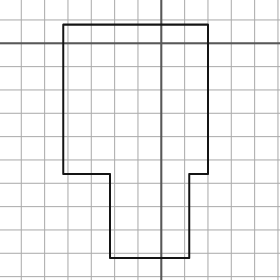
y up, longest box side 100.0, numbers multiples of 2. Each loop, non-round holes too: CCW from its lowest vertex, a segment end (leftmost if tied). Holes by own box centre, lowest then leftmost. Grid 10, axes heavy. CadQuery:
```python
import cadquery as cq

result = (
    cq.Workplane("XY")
    .moveTo(-22.0, -92.0)
    .lineTo(12.0, -92.0)
    .lineTo(12.0, -56.0)
    .lineTo(20.0, -56.0)
    .lineTo(20.0, 8.0)
    .lineTo(-42.0, 8.0)
    .lineTo(-42.0, -56.0)
    .lineTo(-22.0, -56.0)
    .close()
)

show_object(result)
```